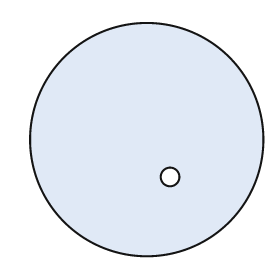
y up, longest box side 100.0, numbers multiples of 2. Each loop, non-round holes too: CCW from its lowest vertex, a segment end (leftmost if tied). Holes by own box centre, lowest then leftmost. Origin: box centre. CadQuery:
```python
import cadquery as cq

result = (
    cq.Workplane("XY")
    .moveTo(0.0, 0.0)
    .circle(50.0)
    .moveTo(10.0, -16.0)
    .circle(4.0)
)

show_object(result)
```